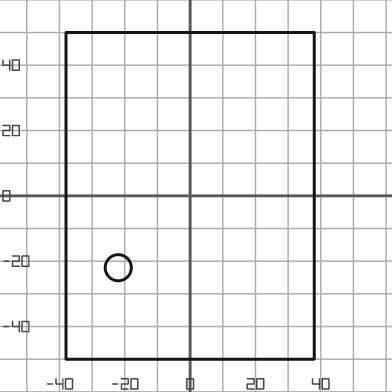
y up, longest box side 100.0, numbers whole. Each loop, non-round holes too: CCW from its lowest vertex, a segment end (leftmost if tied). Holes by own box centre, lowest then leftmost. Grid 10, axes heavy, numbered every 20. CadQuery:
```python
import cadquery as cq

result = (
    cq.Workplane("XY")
    .moveTo(-38.0, -50.0)
    .lineTo(38.0, -50.0)
    .lineTo(38.0, 50.0)
    .lineTo(-38.0, 50.0)
    .close()
    .moveTo(-22.0, -22.0)
    .circle(4.0)
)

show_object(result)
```